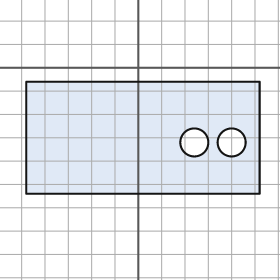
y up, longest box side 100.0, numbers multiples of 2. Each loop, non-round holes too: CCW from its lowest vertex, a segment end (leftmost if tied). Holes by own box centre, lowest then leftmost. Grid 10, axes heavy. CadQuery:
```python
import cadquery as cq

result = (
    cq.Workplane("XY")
    .moveTo(-48.0, -54.0)
    .lineTo(52.0, -54.0)
    .lineTo(52.0, -6.0)
    .lineTo(-48.0, -6.0)
    .close()
    .moveTo(24.0, -32.0)
    .circle(6.0)
    .moveTo(40.0, -32.0)
    .circle(6.0)
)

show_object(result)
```